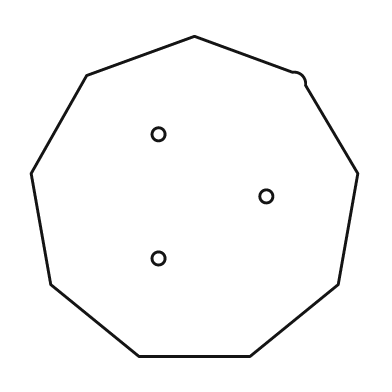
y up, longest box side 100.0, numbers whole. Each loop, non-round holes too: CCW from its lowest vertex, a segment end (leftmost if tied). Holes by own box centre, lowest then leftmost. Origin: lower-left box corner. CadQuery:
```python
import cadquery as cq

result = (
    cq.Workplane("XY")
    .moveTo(33.0, 0.0)
    .lineTo(67.0, 0.0)
    .lineTo(94.0, 22.0)
    .lineTo(100.0, 56.0)
    .lineTo(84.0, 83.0)
    .threePointArc((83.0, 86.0), (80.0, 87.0))
    .lineTo(50.0, 98.0)
    .lineTo(17.0, 86.0)
    .lineTo(0.0, 56.0)
    .lineTo(6.0, 22.0)
    .close()
    .moveTo(39.0, 30.0)
    .circle(2.0)
    .moveTo(72.0, 49.0)
    .circle(2.0)
    .moveTo(39.0, 68.0)
    .circle(2.0)
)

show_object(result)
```